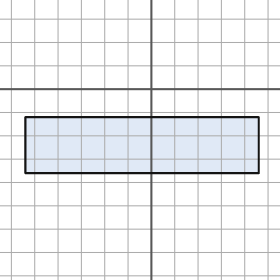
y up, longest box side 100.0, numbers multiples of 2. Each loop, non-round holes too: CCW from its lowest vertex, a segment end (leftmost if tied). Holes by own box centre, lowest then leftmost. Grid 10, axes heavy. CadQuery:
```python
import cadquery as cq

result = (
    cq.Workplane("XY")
    .moveTo(-54.0, -36.0)
    .lineTo(46.0, -36.0)
    .lineTo(46.0, -12.0)
    .lineTo(-54.0, -12.0)
    .close()
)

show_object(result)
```